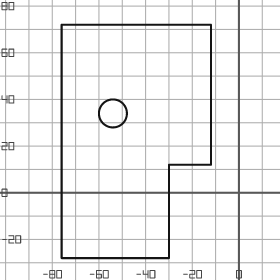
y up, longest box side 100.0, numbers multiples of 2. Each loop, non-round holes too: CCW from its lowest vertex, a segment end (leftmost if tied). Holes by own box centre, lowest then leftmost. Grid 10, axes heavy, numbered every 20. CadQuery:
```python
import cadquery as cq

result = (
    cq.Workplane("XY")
    .moveTo(-76.0, -28.0)
    .lineTo(-30.0, -28.0)
    .lineTo(-30.0, 12.0)
    .lineTo(-12.0, 12.0)
    .lineTo(-12.0, 72.0)
    .lineTo(-76.0, 72.0)
    .close()
    .moveTo(-54.0, 34.0)
    .circle(6.0)
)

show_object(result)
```